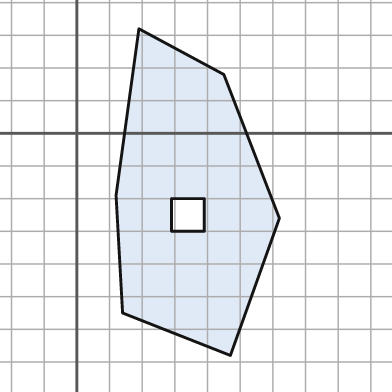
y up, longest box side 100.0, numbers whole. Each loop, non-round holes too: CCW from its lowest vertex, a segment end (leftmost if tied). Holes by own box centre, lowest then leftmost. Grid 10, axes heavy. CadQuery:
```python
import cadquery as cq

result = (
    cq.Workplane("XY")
    .moveTo(47.0, -68.0)
    .lineTo(62.0, -26.0)
    .lineTo(45.0, 18.0)
    .lineTo(19.0, 32.0)
    .lineTo(12.0, -19.0)
    .lineTo(14.0, -55.0)
    .close()
    .moveTo(29.0, -30.0)
    .lineTo(39.0, -30.0)
    .lineTo(39.0, -20.0)
    .lineTo(29.0, -20.0)
    .close()
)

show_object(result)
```